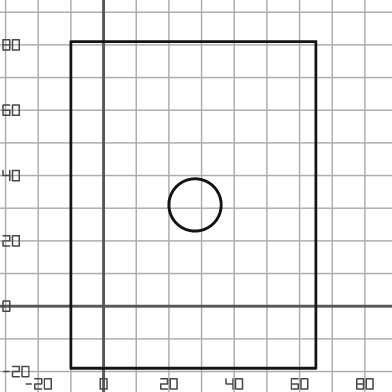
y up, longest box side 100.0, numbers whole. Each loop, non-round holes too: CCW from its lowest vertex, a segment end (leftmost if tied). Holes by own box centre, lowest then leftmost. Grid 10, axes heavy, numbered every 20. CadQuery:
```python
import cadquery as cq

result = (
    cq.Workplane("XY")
    .moveTo(-10.0, -19.0)
    .lineTo(65.0, -19.0)
    .lineTo(65.0, 81.0)
    .lineTo(-10.0, 81.0)
    .close()
    .moveTo(28.0, 31.0)
    .circle(8.0)
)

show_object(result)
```